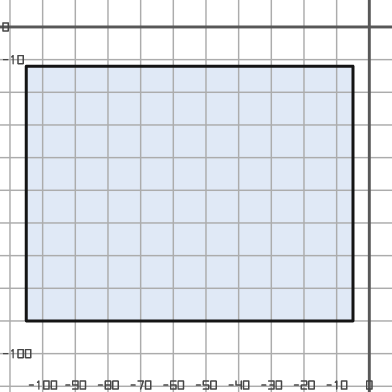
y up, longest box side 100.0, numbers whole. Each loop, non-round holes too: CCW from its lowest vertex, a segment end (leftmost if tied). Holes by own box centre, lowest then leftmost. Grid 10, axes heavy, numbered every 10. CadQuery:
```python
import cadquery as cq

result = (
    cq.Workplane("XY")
    .moveTo(-105.0, -90.0)
    .lineTo(-5.0, -90.0)
    .lineTo(-5.0, -12.0)
    .lineTo(-105.0, -12.0)
    .close()
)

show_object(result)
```